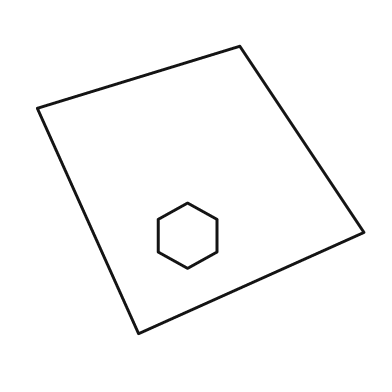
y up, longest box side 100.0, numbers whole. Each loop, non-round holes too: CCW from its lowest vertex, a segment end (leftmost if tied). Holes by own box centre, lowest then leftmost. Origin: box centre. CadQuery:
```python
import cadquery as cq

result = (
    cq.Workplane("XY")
    .moveTo(-19.0, -44.0)
    .lineTo(50.0, -13.0)
    .lineTo(12.0, 44.0)
    .lineTo(-50.0, 25.0)
    .close()
    .moveTo(-4.0, -24.0)
    .lineTo(5.0, -19.0)
    .lineTo(5.0, -9.0)
    .lineTo(-4.0, -4.0)
    .lineTo(-13.0, -9.0)
    .lineTo(-13.0, -19.0)
    .close()
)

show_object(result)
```